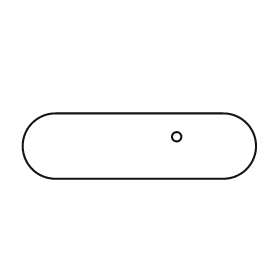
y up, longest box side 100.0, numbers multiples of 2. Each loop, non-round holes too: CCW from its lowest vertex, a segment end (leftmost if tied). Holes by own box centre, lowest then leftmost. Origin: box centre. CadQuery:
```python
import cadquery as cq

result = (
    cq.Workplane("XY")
    .moveTo(-36.0, -14.0)
    .lineTo(36.0, -14.0)
    .threePointArc((50.0, 0.0), (36.0, 14.0))
    .lineTo(-36.0, 14.0)
    .threePointArc((-50.0, 0.0), (-36.0, -14.0))
    .close()
    .moveTo(16.0, 4.0)
    .circle(2.0)
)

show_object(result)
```